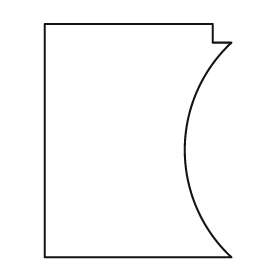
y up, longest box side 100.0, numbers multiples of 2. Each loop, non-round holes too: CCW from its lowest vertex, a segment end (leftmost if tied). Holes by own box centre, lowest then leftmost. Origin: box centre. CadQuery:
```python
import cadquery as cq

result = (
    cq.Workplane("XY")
    .moveTo(-40.0, -50.0)
    .lineTo(40.0, -50.0)
    .threePointArc((20.0, -4.0), (40.0, 42.0))
    .lineTo(32.0, 42.0)
    .lineTo(32.0, 50.0)
    .lineTo(-40.0, 50.0)
    .close()
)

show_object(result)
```